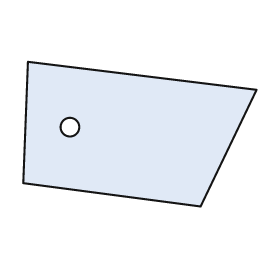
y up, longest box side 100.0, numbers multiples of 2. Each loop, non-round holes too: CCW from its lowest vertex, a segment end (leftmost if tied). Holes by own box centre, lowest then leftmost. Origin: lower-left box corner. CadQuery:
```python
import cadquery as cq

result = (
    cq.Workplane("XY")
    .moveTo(76.0, 0.0)
    .lineTo(100.0, 50.0)
    .lineTo(2.0, 62.0)
    .lineTo(0.0, 10.0)
    .close()
    .moveTo(20.0, 34.0)
    .circle(4.0)
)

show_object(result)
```